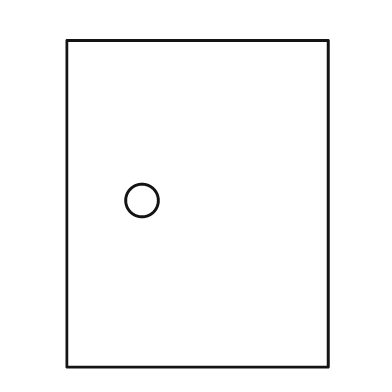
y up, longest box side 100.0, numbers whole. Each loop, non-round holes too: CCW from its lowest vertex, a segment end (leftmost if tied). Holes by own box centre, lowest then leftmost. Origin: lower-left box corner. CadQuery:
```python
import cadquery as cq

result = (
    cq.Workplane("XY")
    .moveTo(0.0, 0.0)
    .lineTo(80.0, 0.0)
    .lineTo(80.0, 100.0)
    .lineTo(0.0, 100.0)
    .close()
    .moveTo(23.0, 51.0)
    .circle(5.0)
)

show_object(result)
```